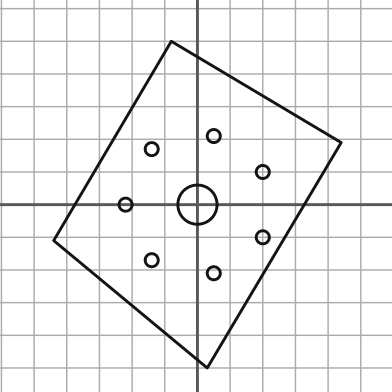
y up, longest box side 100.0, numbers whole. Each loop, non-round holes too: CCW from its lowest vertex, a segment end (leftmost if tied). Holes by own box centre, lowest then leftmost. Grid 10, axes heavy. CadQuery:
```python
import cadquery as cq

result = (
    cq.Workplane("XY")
    .moveTo(3.0, -50.0)
    .lineTo(44.0, 19.0)
    .lineTo(-8.0, 50.0)
    .lineTo(-44.0, -11.0)
    .close()
    .moveTo(5.0, -21.0)
    .circle(2.0)
    .moveTo(-14.0, -17.0)
    .circle(2.0)
    .moveTo(20.0, -10.0)
    .circle(2.0)
    .moveTo(-22.0, 0.0)
    .circle(2.0)
    .moveTo(0.0, 0.0)
    .circle(6.0)
    .moveTo(20.0, 10.0)
    .circle(2.0)
    .moveTo(-14.0, 17.0)
    .circle(2.0)
    .moveTo(5.0, 21.0)
    .circle(2.0)
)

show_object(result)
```